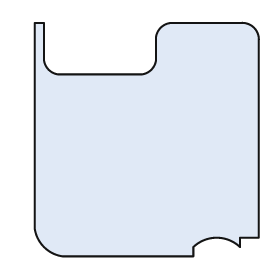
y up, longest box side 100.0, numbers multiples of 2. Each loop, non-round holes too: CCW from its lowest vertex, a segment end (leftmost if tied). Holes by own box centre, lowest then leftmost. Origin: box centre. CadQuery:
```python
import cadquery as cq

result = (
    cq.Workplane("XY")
    .moveTo(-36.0, -50.0)
    .lineTo(20.0, -50.0)
    .lineTo(20.0, -46.0)
    .threePointArc((30.0, -42.0), (40.0, -46.0))
    .lineTo(40.0, -42.0)
    .lineTo(48.0, -42.0)
    .lineTo(48.0, 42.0)
    .threePointArc((46.0, 48.0), (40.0, 50.0))
    .lineTo(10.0, 50.0)
    .threePointArc((6.0, 48.0), (4.0, 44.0))
    .lineTo(4.0, 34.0)
    .threePointArc((2.0, 30.0), (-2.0, 28.0))
    .lineTo(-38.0, 28.0)
    .threePointArc((-42.0, 30.0), (-44.0, 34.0))
    .lineTo(-44.0, 50.0)
    .lineTo(-48.0, 50.0)
    .lineTo(-48.0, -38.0)
    .threePointArc((-44.0, -46.0), (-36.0, -50.0))
    .close()
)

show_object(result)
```